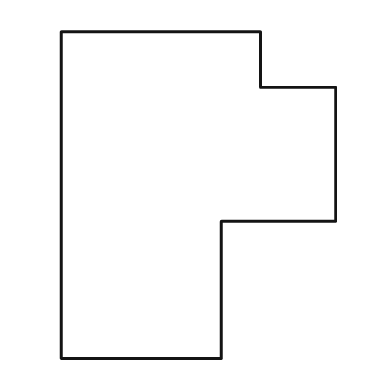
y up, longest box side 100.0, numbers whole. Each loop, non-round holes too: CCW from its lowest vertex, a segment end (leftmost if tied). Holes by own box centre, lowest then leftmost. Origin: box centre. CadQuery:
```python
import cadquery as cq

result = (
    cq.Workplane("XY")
    .moveTo(-42.0, -50.0)
    .lineTo(7.0, -50.0)
    .lineTo(7.0, -8.0)
    .lineTo(42.0, -8.0)
    .lineTo(42.0, 33.0)
    .lineTo(19.0, 33.0)
    .lineTo(19.0, 50.0)
    .lineTo(-42.0, 50.0)
    .close()
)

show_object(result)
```